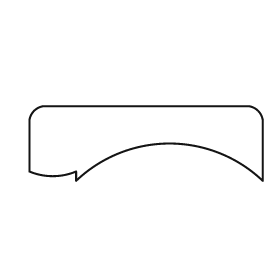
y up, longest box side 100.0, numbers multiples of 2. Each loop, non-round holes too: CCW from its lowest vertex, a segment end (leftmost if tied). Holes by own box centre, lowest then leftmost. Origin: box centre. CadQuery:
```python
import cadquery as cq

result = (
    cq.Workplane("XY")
    .moveTo(-30.0, -16.0)
    .threePointArc((10.0, 0.0), (50.0, -16.0))
    .lineTo(50.0, 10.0)
    .threePointArc((48.0, 14.0), (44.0, 16.0))
    .lineTo(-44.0, 16.0)
    .threePointArc((-48.0, 14.0), (-50.0, 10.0))
    .lineTo(-50.0, -12.0)
    .threePointArc((-40.0, -14.0), (-30.0, -12.0))
    .close()
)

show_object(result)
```